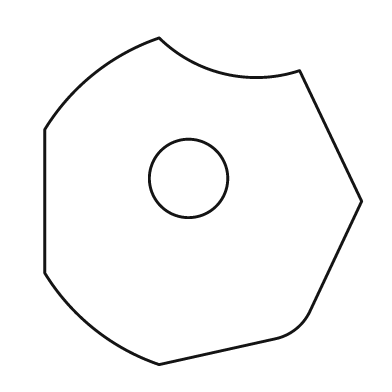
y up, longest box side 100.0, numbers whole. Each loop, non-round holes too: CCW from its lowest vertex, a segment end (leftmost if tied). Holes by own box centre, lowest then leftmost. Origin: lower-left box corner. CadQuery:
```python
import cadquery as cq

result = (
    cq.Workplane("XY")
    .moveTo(35.0, 0.0)
    .lineTo(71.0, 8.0)
    .threePointArc((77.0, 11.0), (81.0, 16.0))
    .lineTo(97.0, 50.0)
    .lineTo(78.0, 90.0)
    .threePointArc((55.0, 89.0), (35.0, 100.0))
    .threePointArc((15.0, 89.0), (0.0, 72.0))
    .lineTo(0.0, 28.0)
    .threePointArc((15.0, 11.0), (35.0, 0.0))
    .close()
    .moveTo(44.0, 57.0)
    .circle(12.0)
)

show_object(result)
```